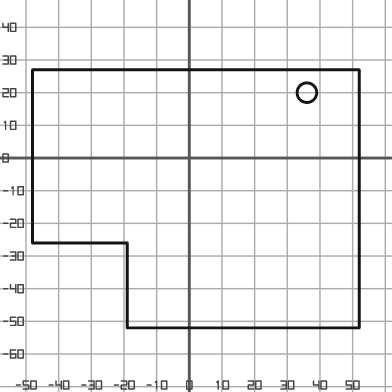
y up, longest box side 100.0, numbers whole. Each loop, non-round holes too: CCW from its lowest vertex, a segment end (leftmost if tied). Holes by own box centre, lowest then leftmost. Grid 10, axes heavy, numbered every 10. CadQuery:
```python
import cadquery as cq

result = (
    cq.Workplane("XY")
    .moveTo(-19.0, -52.0)
    .lineTo(52.0, -52.0)
    .lineTo(52.0, 27.0)
    .lineTo(-48.0, 27.0)
    .lineTo(-48.0, -26.0)
    .lineTo(-19.0, -26.0)
    .close()
    .moveTo(36.0, 20.0)
    .circle(3.0)
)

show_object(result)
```